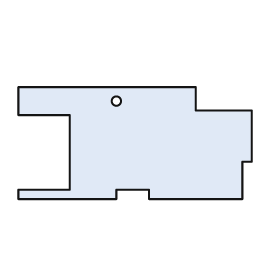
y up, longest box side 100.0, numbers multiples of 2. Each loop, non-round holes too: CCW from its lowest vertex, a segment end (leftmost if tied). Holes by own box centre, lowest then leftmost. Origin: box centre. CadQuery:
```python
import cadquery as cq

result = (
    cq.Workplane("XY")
    .moveTo(-50.0, -24.0)
    .lineTo(-8.0, -24.0)
    .lineTo(-8.0, -20.0)
    .lineTo(6.0, -20.0)
    .lineTo(6.0, -24.0)
    .lineTo(46.0, -24.0)
    .lineTo(46.0, -8.0)
    .lineTo(50.0, -8.0)
    .lineTo(50.0, 14.0)
    .lineTo(26.0, 14.0)
    .lineTo(26.0, 24.0)
    .lineTo(-50.0, 24.0)
    .lineTo(-50.0, 12.0)
    .lineTo(-28.0, 12.0)
    .lineTo(-28.0, -20.0)
    .lineTo(-50.0, -20.0)
    .close()
    .moveTo(-8.0, 18.0)
    .circle(2.0)
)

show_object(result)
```